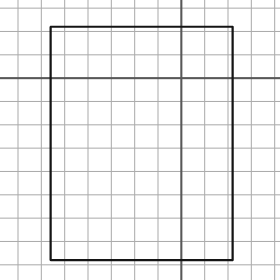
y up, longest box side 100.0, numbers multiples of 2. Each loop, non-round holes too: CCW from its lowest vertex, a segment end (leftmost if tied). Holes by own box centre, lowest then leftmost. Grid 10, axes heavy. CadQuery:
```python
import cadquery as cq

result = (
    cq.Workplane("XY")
    .moveTo(-56.0, -78.0)
    .lineTo(22.0, -78.0)
    .lineTo(22.0, 22.0)
    .lineTo(-56.0, 22.0)
    .close()
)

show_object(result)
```